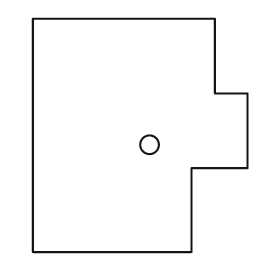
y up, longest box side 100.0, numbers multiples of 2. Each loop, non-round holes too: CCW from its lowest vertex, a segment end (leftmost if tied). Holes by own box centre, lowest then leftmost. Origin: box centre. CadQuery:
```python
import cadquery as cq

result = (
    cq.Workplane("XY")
    .moveTo(-46.0, -50.0)
    .lineTo(22.0, -50.0)
    .lineTo(22.0, -14.0)
    .lineTo(46.0, -14.0)
    .lineTo(46.0, 18.0)
    .lineTo(32.0, 18.0)
    .lineTo(32.0, 50.0)
    .lineTo(-46.0, 50.0)
    .close()
    .moveTo(4.0, -4.0)
    .circle(4.0)
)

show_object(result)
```